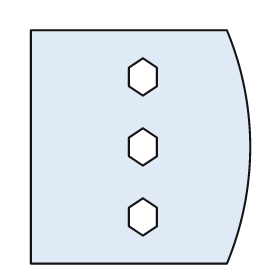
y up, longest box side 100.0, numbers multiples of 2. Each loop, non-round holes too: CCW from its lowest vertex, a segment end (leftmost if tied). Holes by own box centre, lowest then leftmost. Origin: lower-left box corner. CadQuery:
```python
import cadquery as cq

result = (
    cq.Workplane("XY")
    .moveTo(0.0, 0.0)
    .lineTo(84.0, 0.0)
    .threePointArc((94.0, 50.0), (84.0, 100.0))
    .lineTo(0.0, 100.0)
    .close()
    .moveTo(48.0, 12.0)
    .lineTo(54.0, 16.0)
    .lineTo(54.0, 24.0)
    .lineTo(48.0, 28.0)
    .lineTo(42.0, 24.0)
    .lineTo(42.0, 16.0)
    .close()
    .moveTo(48.0, 42.0)
    .lineTo(54.0, 46.0)
    .lineTo(54.0, 54.0)
    .lineTo(48.0, 58.0)
    .lineTo(42.0, 54.0)
    .lineTo(42.0, 46.0)
    .close()
    .moveTo(48.0, 72.0)
    .lineTo(54.0, 76.0)
    .lineTo(54.0, 84.0)
    .lineTo(48.0, 88.0)
    .lineTo(42.0, 84.0)
    .lineTo(42.0, 76.0)
    .close()
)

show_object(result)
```